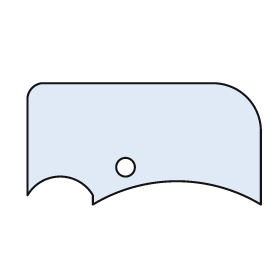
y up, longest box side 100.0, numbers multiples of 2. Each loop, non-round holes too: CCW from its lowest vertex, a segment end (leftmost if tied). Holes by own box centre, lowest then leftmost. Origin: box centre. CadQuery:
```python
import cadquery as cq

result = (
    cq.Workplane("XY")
    .moveTo(-22.0, -26.0)
    .threePointArc((14.0, -16.0), (50.0, -26.0))
    .lineTo(50.0, 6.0)
    .threePointArc((44.0, 20.0), (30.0, 26.0))
    .lineTo(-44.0, 26.0)
    .threePointArc((-48.0, 24.0), (-50.0, 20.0))
    .lineTo(-50.0, -22.0)
    .threePointArc((-36.0, -14.0), (-22.0, -22.0))
    .close()
    .moveTo(-8.0, -10.0)
    .circle(4.0)
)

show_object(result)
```